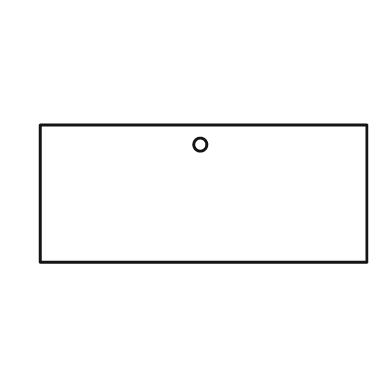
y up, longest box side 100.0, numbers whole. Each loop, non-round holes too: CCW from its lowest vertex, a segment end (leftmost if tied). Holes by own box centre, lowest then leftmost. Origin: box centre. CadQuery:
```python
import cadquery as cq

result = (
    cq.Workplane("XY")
    .moveTo(-50.0, -21.0)
    .lineTo(50.0, -21.0)
    .lineTo(50.0, 21.0)
    .lineTo(-50.0, 21.0)
    .close()
    .moveTo(-1.0, 15.0)
    .circle(2.0)
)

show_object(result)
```